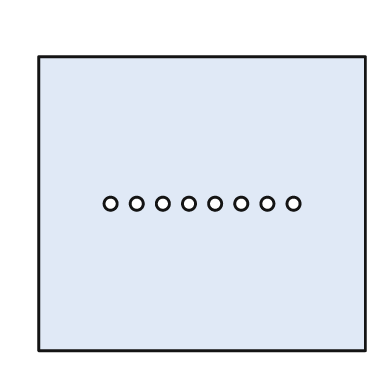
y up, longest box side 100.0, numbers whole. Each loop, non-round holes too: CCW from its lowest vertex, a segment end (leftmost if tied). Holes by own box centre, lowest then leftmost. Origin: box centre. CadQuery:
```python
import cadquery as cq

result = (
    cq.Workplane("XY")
    .moveTo(-50.0, -45.0)
    .lineTo(50.0, -45.0)
    .lineTo(50.0, 45.0)
    .lineTo(-50.0, 45.0)
    .close()
    .moveTo(-28.0, 0.0)
    .circle(2.0)
    .moveTo(-20.0, 0.0)
    .circle(2.0)
    .moveTo(-12.0, 0.0)
    .circle(2.0)
    .moveTo(-4.0, 0.0)
    .circle(2.0)
    .moveTo(4.0, 0.0)
    .circle(2.0)
    .moveTo(12.0, 0.0)
    .circle(2.0)
    .moveTo(20.0, 0.0)
    .circle(2.0)
    .moveTo(28.0, 0.0)
    .circle(2.0)
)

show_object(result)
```